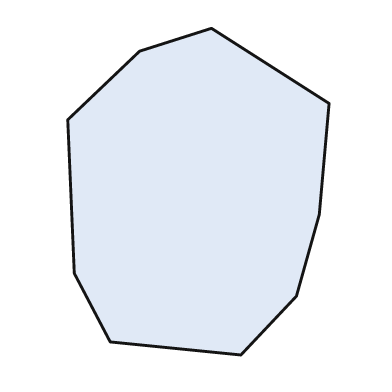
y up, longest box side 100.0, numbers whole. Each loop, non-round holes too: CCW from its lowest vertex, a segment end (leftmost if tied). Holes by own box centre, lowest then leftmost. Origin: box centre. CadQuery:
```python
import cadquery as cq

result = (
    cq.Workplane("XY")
    .moveTo(13.0, -50.0)
    .lineTo(30.0, -32.0)
    .lineTo(37.0, -7.0)
    .lineTo(40.0, 27.0)
    .lineTo(4.0, 50.0)
    .lineTo(-18.0, 43.0)
    .lineTo(-40.0, 22.0)
    .lineTo(-38.0, -25.0)
    .lineTo(-27.0, -46.0)
    .close()
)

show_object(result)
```